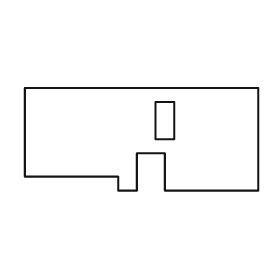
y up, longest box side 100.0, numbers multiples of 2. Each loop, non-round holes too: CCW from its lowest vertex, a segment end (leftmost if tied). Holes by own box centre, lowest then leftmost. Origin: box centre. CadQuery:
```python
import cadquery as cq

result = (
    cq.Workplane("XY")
    .moveTo(-10.0, -22.0)
    .lineTo(-2.0, -22.0)
    .lineTo(-2.0, -6.0)
    .lineTo(10.0, -6.0)
    .lineTo(10.0, -22.0)
    .lineTo(50.0, -22.0)
    .lineTo(50.0, 22.0)
    .lineTo(-50.0, 22.0)
    .lineTo(-50.0, -16.0)
    .lineTo(-10.0, -16.0)
    .close()
    .moveTo(6.0, 0.0)
    .lineTo(14.0, 0.0)
    .lineTo(14.0, 16.0)
    .lineTo(6.0, 16.0)
    .close()
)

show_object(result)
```